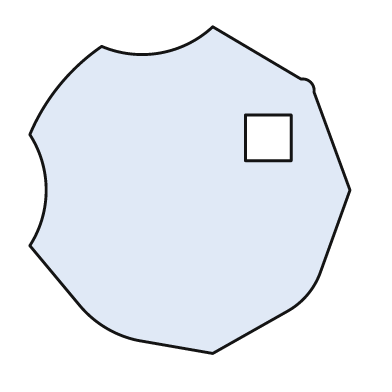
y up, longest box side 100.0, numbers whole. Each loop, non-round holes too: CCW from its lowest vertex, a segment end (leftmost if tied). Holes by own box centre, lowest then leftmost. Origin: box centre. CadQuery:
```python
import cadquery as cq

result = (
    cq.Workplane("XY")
    .moveTo(7.0, -50.0)
    .lineTo(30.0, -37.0)
    .threePointArc((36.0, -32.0), (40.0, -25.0))
    .lineTo(49.0, 0.0)
    .lineTo(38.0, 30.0)
    .threePointArc((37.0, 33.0), (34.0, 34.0))
    .lineTo(7.0, 50.0)
    .threePointArc((-9.0, 42.0), (-27.0, 44.0))
    .threePointArc((-40.0, 32.0), (-49.0, 17.0))
    .threePointArc((-44.0, 0.0), (-49.0, -17.0))
    .lineTo(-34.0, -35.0)
    .threePointArc((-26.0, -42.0), (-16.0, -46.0))
    .close()
    .moveTo(17.0, 9.0)
    .lineTo(31.0, 9.0)
    .lineTo(31.0, 23.0)
    .lineTo(17.0, 23.0)
    .close()
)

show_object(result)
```